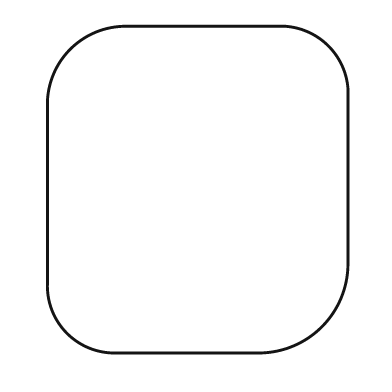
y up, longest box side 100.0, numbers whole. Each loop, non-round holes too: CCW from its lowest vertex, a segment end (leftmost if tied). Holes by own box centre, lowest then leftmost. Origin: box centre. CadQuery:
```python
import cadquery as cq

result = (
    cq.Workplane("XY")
    .moveTo(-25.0, -50.0)
    .lineTo(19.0, -50.0)
    .threePointArc((38.0, -42.0), (46.0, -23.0))
    .lineTo(46.0, 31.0)
    .threePointArc((40.0, 44.0), (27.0, 50.0))
    .lineTo(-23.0, 50.0)
    .threePointArc((-39.0, 43.0), (-46.0, 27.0))
    .lineTo(-46.0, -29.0)
    .threePointArc((-40.0, -44.0), (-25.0, -50.0))
    .close()
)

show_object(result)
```